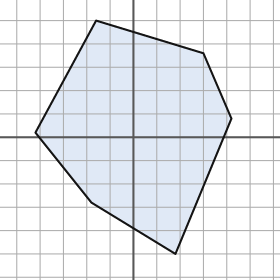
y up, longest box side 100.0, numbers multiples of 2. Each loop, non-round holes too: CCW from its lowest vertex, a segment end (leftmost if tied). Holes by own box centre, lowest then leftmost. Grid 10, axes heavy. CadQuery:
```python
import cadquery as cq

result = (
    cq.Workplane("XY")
    .moveTo(18.0, -50.0)
    .lineTo(42.0, 8.0)
    .lineTo(30.0, 36.0)
    .lineTo(-16.0, 50.0)
    .lineTo(-42.0, 2.0)
    .lineTo(-18.0, -28.0)
    .close()
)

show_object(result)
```